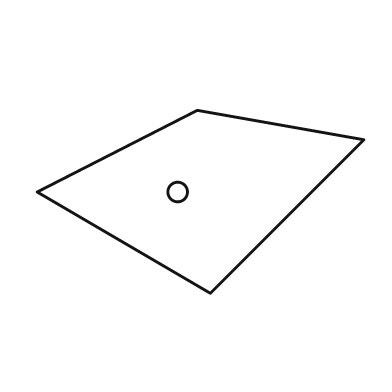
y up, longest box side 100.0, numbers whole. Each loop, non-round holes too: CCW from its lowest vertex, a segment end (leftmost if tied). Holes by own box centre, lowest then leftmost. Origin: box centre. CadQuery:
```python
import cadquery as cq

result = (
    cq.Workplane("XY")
    .moveTo(3.0, -28.0)
    .lineTo(50.0, 19.0)
    .lineTo(-1.0, 28.0)
    .lineTo(-50.0, 3.0)
    .close()
    .moveTo(-7.0, 3.0)
    .circle(3.0)
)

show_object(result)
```